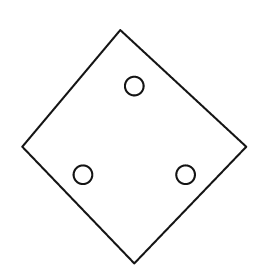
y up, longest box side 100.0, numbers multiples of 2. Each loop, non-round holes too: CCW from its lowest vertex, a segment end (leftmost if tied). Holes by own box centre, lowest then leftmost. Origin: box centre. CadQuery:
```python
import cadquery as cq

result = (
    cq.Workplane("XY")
    .moveTo(0.0, -50.0)
    .lineTo(48.0, 0.0)
    .lineTo(-6.0, 50.0)
    .lineTo(-48.0, 0.0)
    .close()
    .moveTo(-22.0, -12.0)
    .circle(4.0)
    .moveTo(22.0, -12.0)
    .circle(4.0)
    .moveTo(0.0, 26.0)
    .circle(4.0)
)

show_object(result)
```